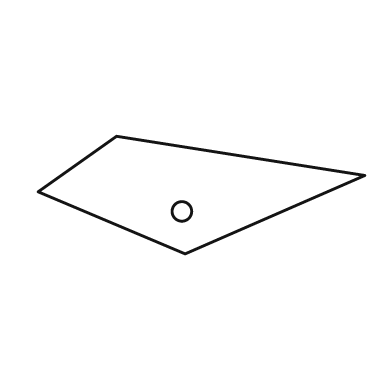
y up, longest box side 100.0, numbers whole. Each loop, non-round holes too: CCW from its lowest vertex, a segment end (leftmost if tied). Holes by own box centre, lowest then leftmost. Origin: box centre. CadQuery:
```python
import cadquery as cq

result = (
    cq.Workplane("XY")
    .moveTo(-5.0, -18.0)
    .lineTo(50.0, 6.0)
    .lineTo(-26.0, 18.0)
    .lineTo(-50.0, 1.0)
    .close()
    .moveTo(-6.0, -5.0)
    .circle(3.0)
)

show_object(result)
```